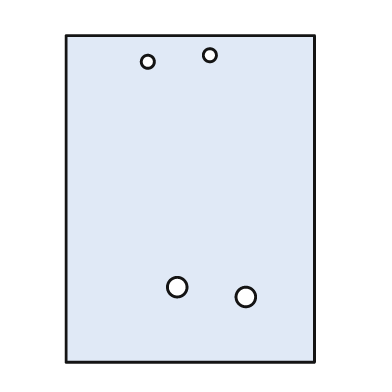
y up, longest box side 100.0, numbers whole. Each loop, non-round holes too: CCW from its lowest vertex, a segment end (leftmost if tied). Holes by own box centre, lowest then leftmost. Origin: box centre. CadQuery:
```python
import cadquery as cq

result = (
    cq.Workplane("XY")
    .moveTo(-38.0, -50.0)
    .lineTo(38.0, -50.0)
    .lineTo(38.0, 50.0)
    .lineTo(-38.0, 50.0)
    .close()
    .moveTo(17.0, -30.0)
    .circle(3.0)
    .moveTo(-4.0, -27.0)
    .circle(3.0)
    .moveTo(-13.0, 42.0)
    .circle(2.0)
    .moveTo(6.0, 44.0)
    .circle(2.0)
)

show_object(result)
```